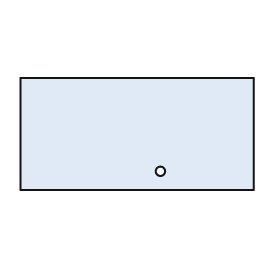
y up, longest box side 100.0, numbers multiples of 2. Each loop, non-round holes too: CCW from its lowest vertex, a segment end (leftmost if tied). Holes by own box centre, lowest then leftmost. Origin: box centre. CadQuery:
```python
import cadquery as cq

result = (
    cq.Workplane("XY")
    .moveTo(-50.0, -24.0)
    .lineTo(50.0, -24.0)
    .lineTo(50.0, 24.0)
    .lineTo(-50.0, 24.0)
    .close()
    .moveTo(10.0, -16.0)
    .circle(2.0)
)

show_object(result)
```